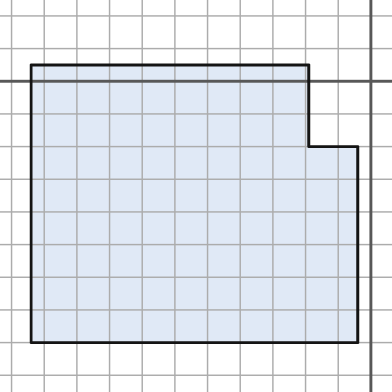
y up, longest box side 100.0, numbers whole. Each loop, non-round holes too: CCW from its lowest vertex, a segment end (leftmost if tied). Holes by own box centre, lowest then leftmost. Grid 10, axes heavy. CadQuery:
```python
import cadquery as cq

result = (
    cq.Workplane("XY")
    .moveTo(-104.0, -80.0)
    .lineTo(-4.0, -80.0)
    .lineTo(-4.0, -20.0)
    .lineTo(-19.0, -20.0)
    .lineTo(-19.0, 5.0)
    .lineTo(-104.0, 5.0)
    .close()
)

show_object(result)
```